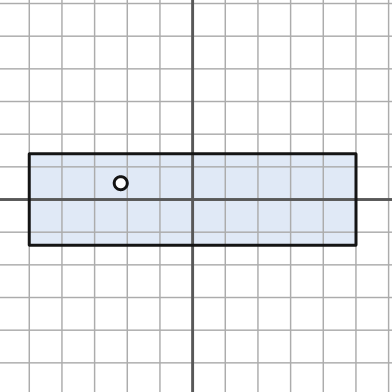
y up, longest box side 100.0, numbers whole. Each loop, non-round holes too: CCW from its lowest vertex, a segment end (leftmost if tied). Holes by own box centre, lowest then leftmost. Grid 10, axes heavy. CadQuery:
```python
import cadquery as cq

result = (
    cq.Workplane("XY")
    .moveTo(-50.0, -14.0)
    .lineTo(50.0, -14.0)
    .lineTo(50.0, 14.0)
    .lineTo(-50.0, 14.0)
    .close()
    .moveTo(-22.0, 5.0)
    .circle(2.0)
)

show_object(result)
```